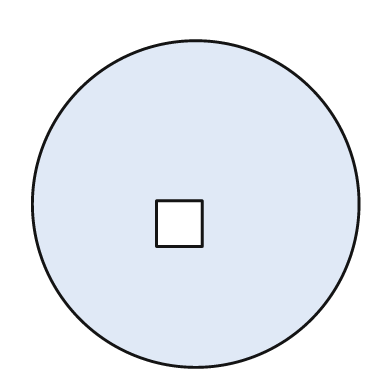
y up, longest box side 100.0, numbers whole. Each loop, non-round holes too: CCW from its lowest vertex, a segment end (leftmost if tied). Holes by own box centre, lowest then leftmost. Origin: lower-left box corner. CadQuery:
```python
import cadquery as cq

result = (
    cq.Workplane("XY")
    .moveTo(50.0, 50.0)
    .circle(50.0)
    .moveTo(38.0, 37.0)
    .lineTo(52.0, 37.0)
    .lineTo(52.0, 51.0)
    .lineTo(38.0, 51.0)
    .close()
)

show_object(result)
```